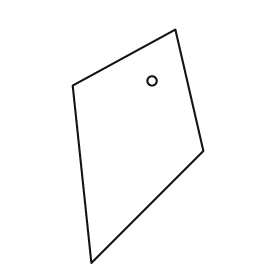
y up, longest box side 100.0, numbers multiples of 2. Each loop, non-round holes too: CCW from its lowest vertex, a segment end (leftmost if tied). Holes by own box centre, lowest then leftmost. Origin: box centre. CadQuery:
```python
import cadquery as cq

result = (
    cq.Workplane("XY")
    .moveTo(-20.0, -50.0)
    .lineTo(28.0, -2.0)
    .lineTo(16.0, 50.0)
    .lineTo(-28.0, 26.0)
    .close()
    .moveTo(6.0, 28.0)
    .circle(2.0)
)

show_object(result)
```